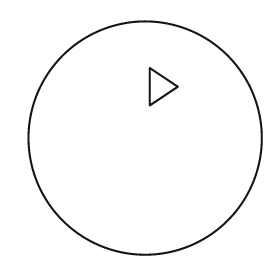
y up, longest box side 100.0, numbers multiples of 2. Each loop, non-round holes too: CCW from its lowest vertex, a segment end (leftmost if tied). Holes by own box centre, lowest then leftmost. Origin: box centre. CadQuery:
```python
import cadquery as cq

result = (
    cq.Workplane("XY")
    .moveTo(0.0, 0.0)
    .circle(50.0)
    .moveTo(2.0, 14.0)
    .lineTo(14.0, 22.0)
    .lineTo(2.0, 30.0)
    .close()
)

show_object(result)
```